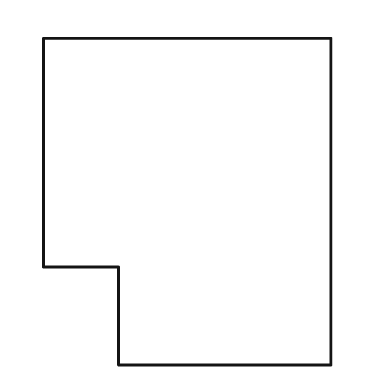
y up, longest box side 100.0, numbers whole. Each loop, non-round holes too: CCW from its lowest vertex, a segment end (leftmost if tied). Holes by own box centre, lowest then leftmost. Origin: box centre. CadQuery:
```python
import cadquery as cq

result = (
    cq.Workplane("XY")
    .moveTo(-21.0, -50.0)
    .lineTo(44.0, -50.0)
    .lineTo(44.0, 50.0)
    .lineTo(-44.0, 50.0)
    .lineTo(-44.0, -20.0)
    .lineTo(-21.0, -20.0)
    .close()
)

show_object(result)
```